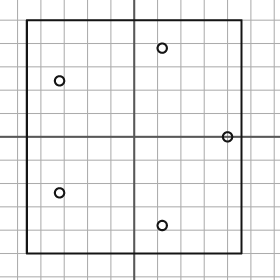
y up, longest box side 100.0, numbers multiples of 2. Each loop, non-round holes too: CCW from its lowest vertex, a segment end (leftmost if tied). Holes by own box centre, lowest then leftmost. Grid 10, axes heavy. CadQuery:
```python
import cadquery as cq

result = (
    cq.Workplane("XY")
    .moveTo(-46.0, -50.0)
    .lineTo(46.0, -50.0)
    .lineTo(46.0, 50.0)
    .lineTo(-46.0, 50.0)
    .close()
    .moveTo(12.0, -38.0)
    .circle(2.0)
    .moveTo(-32.0, -24.0)
    .circle(2.0)
    .moveTo(40.0, 0.0)
    .circle(2.0)
    .moveTo(-32.0, 24.0)
    .circle(2.0)
    .moveTo(12.0, 38.0)
    .circle(2.0)
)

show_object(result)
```